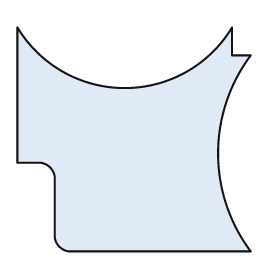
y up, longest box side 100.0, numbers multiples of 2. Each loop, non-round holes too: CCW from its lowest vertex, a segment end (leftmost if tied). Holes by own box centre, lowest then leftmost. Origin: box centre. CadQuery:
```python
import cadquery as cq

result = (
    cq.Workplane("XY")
    .moveTo(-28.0, -48.0)
    .lineTo(50.0, -48.0)
    .threePointArc((36.0, -6.0), (50.0, 36.0))
    .lineTo(42.0, 36.0)
    .lineTo(42.0, 48.0)
    .threePointArc((-4.0, 22.0), (-50.0, 48.0))
    .lineTo(-50.0, -10.0)
    .lineTo(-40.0, -10.0)
    .threePointArc((-36.0, -12.0), (-34.0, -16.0))
    .lineTo(-34.0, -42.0)
    .threePointArc((-32.0, -46.0), (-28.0, -48.0))
    .close()
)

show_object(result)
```